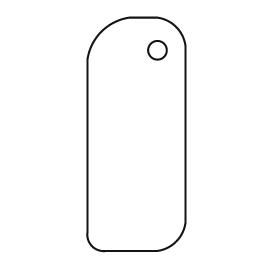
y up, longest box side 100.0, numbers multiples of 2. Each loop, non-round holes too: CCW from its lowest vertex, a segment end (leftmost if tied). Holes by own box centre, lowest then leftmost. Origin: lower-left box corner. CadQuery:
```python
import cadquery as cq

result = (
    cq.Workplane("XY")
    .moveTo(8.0, 0.0)
    .lineTo(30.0, 0.0)
    .threePointArc((38.0, 4.0), (42.0, 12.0))
    .lineTo(42.0, 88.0)
    .threePointArc((38.0, 96.0), (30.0, 100.0))
    .lineTo(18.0, 100.0)
    .threePointArc((6.0, 94.0), (0.0, 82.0))
    .lineTo(0.0, 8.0)
    .threePointArc((2.0, 2.0), (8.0, 0.0))
    .close()
    .moveTo(30.0, 86.0)
    .circle(4.0)
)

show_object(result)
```